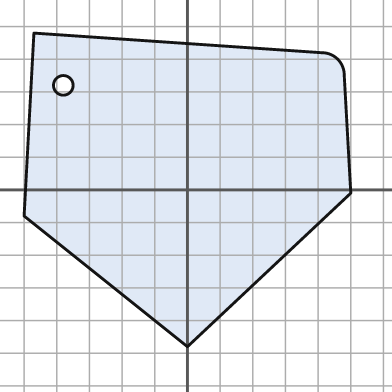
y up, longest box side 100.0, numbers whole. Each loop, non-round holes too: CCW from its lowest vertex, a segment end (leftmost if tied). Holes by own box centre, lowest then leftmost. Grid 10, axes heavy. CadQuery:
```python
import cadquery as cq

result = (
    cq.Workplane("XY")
    .moveTo(0.0, -48.0)
    .lineTo(50.0, -1.0)
    .lineTo(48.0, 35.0)
    .threePointArc((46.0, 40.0), (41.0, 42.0))
    .lineTo(-47.0, 48.0)
    .lineTo(-50.0, -8.0)
    .close()
    .moveTo(-38.0, 32.0)
    .circle(3.0)
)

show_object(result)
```